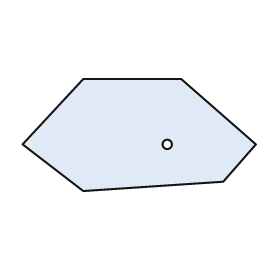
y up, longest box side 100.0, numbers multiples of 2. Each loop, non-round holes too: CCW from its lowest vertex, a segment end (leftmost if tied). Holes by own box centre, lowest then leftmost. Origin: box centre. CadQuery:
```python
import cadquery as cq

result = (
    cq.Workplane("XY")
    .moveTo(-24.0, -24.0)
    .lineTo(36.0, -20.0)
    .lineTo(50.0, -4.0)
    .lineTo(18.0, 24.0)
    .lineTo(-24.0, 24.0)
    .lineTo(-50.0, -4.0)
    .close()
    .moveTo(12.0, -4.0)
    .circle(2.0)
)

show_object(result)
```